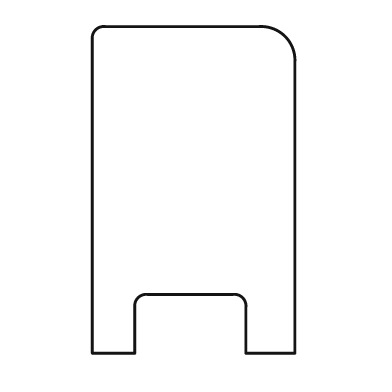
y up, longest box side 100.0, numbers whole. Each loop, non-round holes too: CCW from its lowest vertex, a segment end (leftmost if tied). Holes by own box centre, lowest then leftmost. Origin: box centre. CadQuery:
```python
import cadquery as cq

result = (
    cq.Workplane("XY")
    .moveTo(-31.0, -50.0)
    .lineTo(-18.0, -50.0)
    .lineTo(-18.0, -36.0)
    .threePointArc((-17.0, -33.0), (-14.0, -32.0))
    .lineTo(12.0, -32.0)
    .threePointArc((15.0, -33.0), (16.0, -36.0))
    .lineTo(16.0, -50.0)
    .lineTo(31.0, -50.0)
    .lineTo(31.0, 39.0)
    .threePointArc((28.0, 47.0), (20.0, 50.0))
    .lineTo(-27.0, 50.0)
    .threePointArc((-30.0, 49.0), (-31.0, 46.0))
    .close()
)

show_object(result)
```